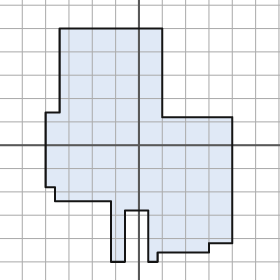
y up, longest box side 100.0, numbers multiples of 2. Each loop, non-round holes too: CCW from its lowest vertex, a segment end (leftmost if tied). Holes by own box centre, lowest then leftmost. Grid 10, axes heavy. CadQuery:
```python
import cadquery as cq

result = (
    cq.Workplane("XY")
    .moveTo(-12.0, -50.0)
    .lineTo(-6.0, -50.0)
    .lineTo(-6.0, -28.0)
    .lineTo(4.0, -28.0)
    .lineTo(4.0, -50.0)
    .lineTo(8.0, -50.0)
    .lineTo(8.0, -46.0)
    .lineTo(30.0, -46.0)
    .lineTo(30.0, -42.0)
    .lineTo(40.0, -42.0)
    .lineTo(40.0, 12.0)
    .lineTo(10.0, 12.0)
    .lineTo(10.0, 50.0)
    .lineTo(-34.0, 50.0)
    .lineTo(-34.0, 14.0)
    .lineTo(-40.0, 14.0)
    .lineTo(-40.0, -18.0)
    .lineTo(-36.0, -18.0)
    .lineTo(-36.0, -24.0)
    .lineTo(-12.0, -24.0)
    .close()
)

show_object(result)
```